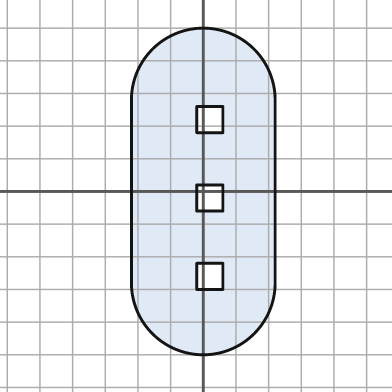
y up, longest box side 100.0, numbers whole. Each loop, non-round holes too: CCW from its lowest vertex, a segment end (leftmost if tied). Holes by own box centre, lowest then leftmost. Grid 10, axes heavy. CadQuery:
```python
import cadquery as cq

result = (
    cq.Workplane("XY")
    .moveTo(-22.0, -28.0)
    .threePointArc((0.0, -50.0), (22.0, -28.0))
    .lineTo(22.0, 28.0)
    .threePointArc((0.0, 50.0), (-22.0, 28.0))
    .close()
    .moveTo(-2.0, -30.0)
    .lineTo(6.0, -30.0)
    .lineTo(6.0, -22.0)
    .lineTo(-2.0, -22.0)
    .close()
    .moveTo(-2.0, -6.0)
    .lineTo(6.0, -6.0)
    .lineTo(6.0, 2.0)
    .lineTo(-2.0, 2.0)
    .close()
    .moveTo(-2.0, 18.0)
    .lineTo(6.0, 18.0)
    .lineTo(6.0, 26.0)
    .lineTo(-2.0, 26.0)
    .close()
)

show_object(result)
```